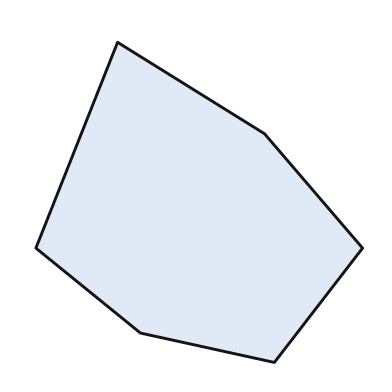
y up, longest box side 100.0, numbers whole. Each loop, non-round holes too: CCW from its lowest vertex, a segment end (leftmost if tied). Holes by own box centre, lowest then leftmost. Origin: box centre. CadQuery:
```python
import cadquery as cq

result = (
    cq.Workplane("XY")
    .moveTo(23.0, -49.0)
    .lineTo(50.0, -14.0)
    .lineTo(20.0, 21.0)
    .lineTo(-25.0, 49.0)
    .lineTo(-50.0, -14.0)
    .lineTo(-18.0, -40.0)
    .close()
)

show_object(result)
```